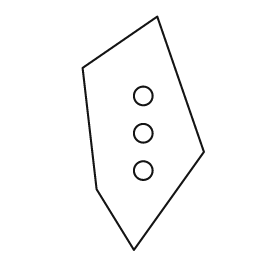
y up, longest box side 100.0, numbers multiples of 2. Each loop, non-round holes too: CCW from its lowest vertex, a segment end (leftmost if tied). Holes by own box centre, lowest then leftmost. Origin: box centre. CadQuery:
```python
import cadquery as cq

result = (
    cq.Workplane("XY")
    .moveTo(-4.0, -50.0)
    .lineTo(26.0, -8.0)
    .lineTo(6.0, 50.0)
    .lineTo(-26.0, 28.0)
    .lineTo(-20.0, -24.0)
    .close()
    .moveTo(0.0, -16.0)
    .circle(4.0)
    .moveTo(0.0, 0.0)
    .circle(4.0)
    .moveTo(0.0, 16.0)
    .circle(4.0)
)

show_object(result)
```